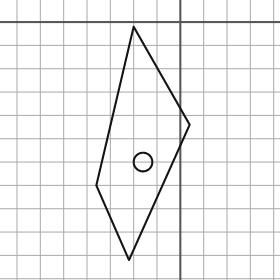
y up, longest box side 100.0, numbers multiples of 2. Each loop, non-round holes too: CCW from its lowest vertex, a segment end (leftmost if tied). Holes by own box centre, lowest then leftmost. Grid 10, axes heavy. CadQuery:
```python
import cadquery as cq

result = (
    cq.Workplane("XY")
    .moveTo(-22.0, -102.0)
    .lineTo(4.0, -44.0)
    .lineTo(-20.0, -2.0)
    .lineTo(-36.0, -70.0)
    .close()
    .moveTo(-16.0, -60.0)
    .circle(4.0)
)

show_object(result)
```